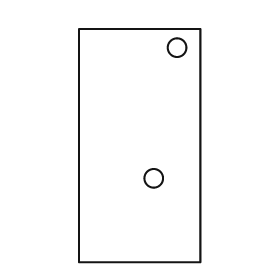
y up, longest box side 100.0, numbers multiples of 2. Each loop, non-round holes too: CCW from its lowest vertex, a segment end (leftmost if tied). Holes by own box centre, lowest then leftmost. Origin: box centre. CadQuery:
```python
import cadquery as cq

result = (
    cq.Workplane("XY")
    .moveTo(-26.0, -50.0)
    .lineTo(26.0, -50.0)
    .lineTo(26.0, 50.0)
    .lineTo(-26.0, 50.0)
    .close()
    .moveTo(6.0, -14.0)
    .circle(4.0)
    .moveTo(16.0, 42.0)
    .circle(4.0)
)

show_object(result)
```